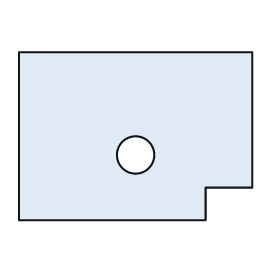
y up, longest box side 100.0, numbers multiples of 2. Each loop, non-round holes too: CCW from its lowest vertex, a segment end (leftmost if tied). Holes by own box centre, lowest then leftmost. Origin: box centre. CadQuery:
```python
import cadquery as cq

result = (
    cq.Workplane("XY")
    .moveTo(-50.0, -36.0)
    .lineTo(30.0, -36.0)
    .lineTo(30.0, -22.0)
    .lineTo(50.0, -22.0)
    .lineTo(50.0, 36.0)
    .lineTo(-50.0, 36.0)
    .close()
    .moveTo(0.0, -8.0)
    .circle(8.0)
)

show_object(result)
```